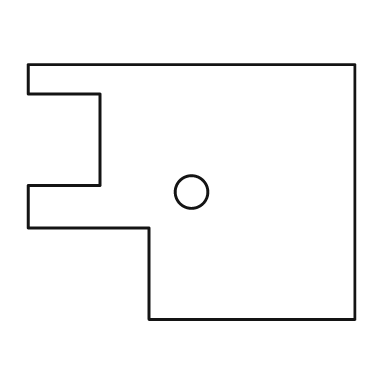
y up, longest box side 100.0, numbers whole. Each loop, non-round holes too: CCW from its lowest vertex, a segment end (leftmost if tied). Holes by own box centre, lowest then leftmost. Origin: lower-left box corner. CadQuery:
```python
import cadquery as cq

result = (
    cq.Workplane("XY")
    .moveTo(37.0, 0.0)
    .lineTo(100.0, 0.0)
    .lineTo(100.0, 78.0)
    .lineTo(0.0, 78.0)
    .lineTo(0.0, 69.0)
    .lineTo(22.0, 69.0)
    .lineTo(22.0, 41.0)
    .lineTo(0.0, 41.0)
    .lineTo(0.0, 28.0)
    .lineTo(37.0, 28.0)
    .close()
    .moveTo(50.0, 39.0)
    .circle(5.0)
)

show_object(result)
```